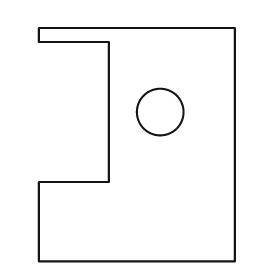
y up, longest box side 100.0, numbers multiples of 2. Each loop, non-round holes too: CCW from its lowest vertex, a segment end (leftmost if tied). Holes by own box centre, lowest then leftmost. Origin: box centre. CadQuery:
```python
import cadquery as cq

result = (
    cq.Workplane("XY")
    .moveTo(-42.0, -50.0)
    .lineTo(42.0, -50.0)
    .lineTo(42.0, 50.0)
    .lineTo(-42.0, 50.0)
    .lineTo(-42.0, 44.0)
    .lineTo(-12.0, 44.0)
    .lineTo(-12.0, -16.0)
    .lineTo(-42.0, -16.0)
    .close()
    .moveTo(10.0, 14.0)
    .circle(10.0)
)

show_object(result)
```